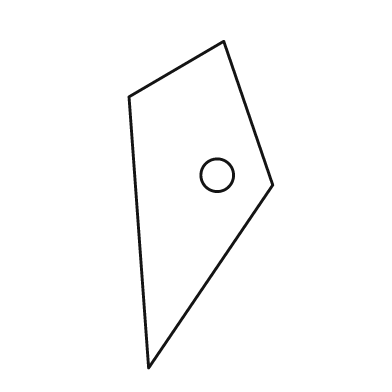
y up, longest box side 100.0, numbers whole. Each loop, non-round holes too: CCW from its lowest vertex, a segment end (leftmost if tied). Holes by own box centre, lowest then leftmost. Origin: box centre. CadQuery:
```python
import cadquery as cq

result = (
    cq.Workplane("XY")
    .moveTo(-16.0, -50.0)
    .lineTo(22.0, 6.0)
    .lineTo(7.0, 50.0)
    .lineTo(-22.0, 33.0)
    .close()
    .moveTo(5.0, 9.0)
    .circle(5.0)
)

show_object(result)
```